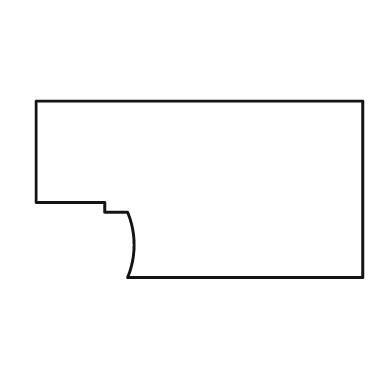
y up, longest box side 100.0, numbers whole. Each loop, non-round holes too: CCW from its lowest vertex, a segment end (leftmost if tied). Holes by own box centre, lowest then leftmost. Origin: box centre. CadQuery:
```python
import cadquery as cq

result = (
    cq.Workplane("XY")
    .moveTo(-22.0, -27.0)
    .lineTo(50.0, -27.0)
    .lineTo(50.0, 27.0)
    .lineTo(-50.0, 27.0)
    .lineTo(-50.0, -4.0)
    .lineTo(-29.0, -4.0)
    .lineTo(-29.0, -7.0)
    .lineTo(-22.0, -7.0)
    .threePointArc((-20.0, -17.0), (-22.0, -27.0))
    .close()
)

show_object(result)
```